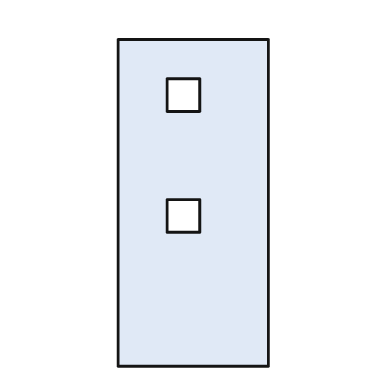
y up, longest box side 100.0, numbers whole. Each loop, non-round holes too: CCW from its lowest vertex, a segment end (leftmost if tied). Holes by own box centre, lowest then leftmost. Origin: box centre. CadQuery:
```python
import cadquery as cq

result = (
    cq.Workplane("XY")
    .moveTo(-23.0, -50.0)
    .lineTo(23.0, -50.0)
    .lineTo(23.0, 50.0)
    .lineTo(-23.0, 50.0)
    .close()
    .moveTo(-8.0, -9.0)
    .lineTo(2.0, -9.0)
    .lineTo(2.0, 1.0)
    .lineTo(-8.0, 1.0)
    .close()
    .moveTo(-8.0, 28.0)
    .lineTo(2.0, 28.0)
    .lineTo(2.0, 38.0)
    .lineTo(-8.0, 38.0)
    .close()
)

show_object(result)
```